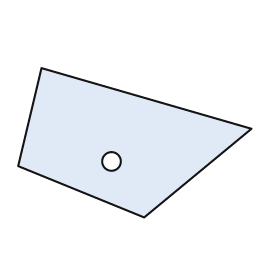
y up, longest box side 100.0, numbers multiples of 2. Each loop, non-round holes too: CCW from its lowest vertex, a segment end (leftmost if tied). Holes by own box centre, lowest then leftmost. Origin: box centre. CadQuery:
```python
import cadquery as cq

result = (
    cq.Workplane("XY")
    .moveTo(4.0, -32.0)
    .lineTo(50.0, 6.0)
    .lineTo(-40.0, 32.0)
    .lineTo(-50.0, -10.0)
    .close()
    .moveTo(-10.0, -8.0)
    .circle(4.0)
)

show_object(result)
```